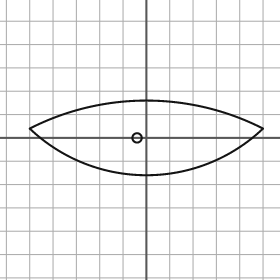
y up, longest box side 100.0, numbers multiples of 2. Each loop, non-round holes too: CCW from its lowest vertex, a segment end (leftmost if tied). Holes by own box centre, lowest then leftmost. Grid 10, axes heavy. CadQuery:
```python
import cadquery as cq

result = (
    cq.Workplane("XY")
    .moveTo(-50.0, 4.0)
    .threePointArc((0.0, -16.0), (50.0, 4.0))
    .threePointArc((0.0, 16.0), (-50.0, 4.0))
    .close()
    .moveTo(-4.0, 0.0)
    .circle(2.0)
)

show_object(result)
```